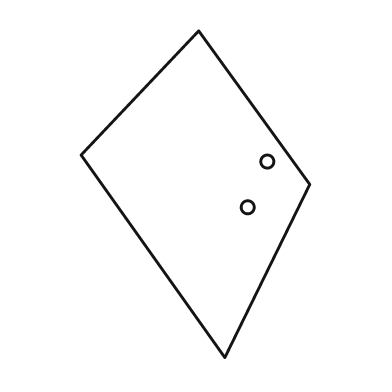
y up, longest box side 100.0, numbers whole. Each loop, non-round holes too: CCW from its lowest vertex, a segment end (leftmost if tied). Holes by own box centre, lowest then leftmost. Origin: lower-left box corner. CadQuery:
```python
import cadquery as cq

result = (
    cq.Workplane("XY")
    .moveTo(44.0, 0.0)
    .lineTo(70.0, 53.0)
    .lineTo(36.0, 100.0)
    .lineTo(0.0, 62.0)
    .close()
    .moveTo(51.0, 46.0)
    .circle(2.0)
    .moveTo(57.0, 60.0)
    .circle(2.0)
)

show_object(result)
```